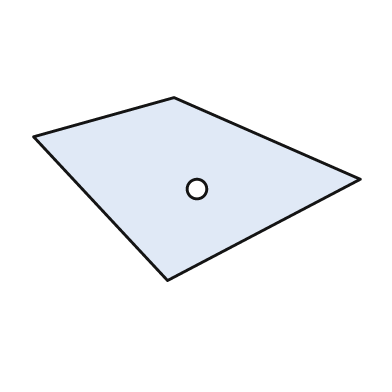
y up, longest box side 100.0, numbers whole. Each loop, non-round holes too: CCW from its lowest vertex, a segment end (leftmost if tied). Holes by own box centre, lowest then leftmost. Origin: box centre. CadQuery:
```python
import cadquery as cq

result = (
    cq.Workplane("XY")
    .moveTo(-9.0, -28.0)
    .lineTo(50.0, 3.0)
    .lineTo(-7.0, 28.0)
    .lineTo(-50.0, 16.0)
    .close()
    .moveTo(0.0, 0.0)
    .circle(3.0)
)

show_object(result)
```